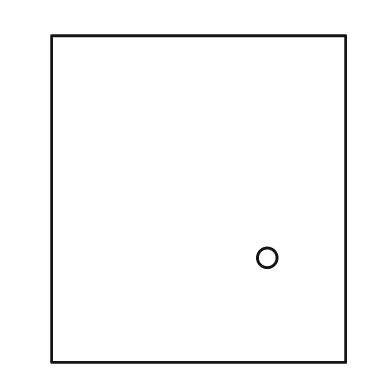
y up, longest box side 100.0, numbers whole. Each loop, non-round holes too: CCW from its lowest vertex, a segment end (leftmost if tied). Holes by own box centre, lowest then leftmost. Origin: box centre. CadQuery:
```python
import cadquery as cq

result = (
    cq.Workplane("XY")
    .moveTo(-45.0, -50.0)
    .lineTo(45.0, -50.0)
    .lineTo(45.0, 50.0)
    .lineTo(-45.0, 50.0)
    .close()
    .moveTo(21.0, -18.0)
    .circle(3.0)
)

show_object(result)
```